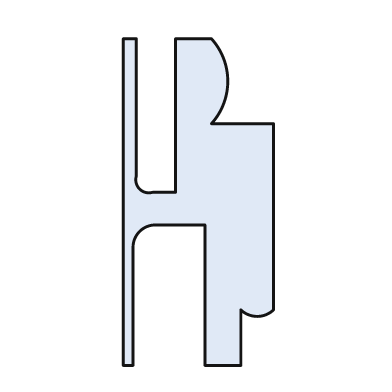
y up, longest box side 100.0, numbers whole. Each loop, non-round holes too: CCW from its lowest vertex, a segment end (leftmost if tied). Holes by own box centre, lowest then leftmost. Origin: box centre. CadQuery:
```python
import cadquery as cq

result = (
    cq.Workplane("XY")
    .moveTo(-23.0, -50.0)
    .lineTo(-20.0, -50.0)
    .lineTo(-20.0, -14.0)
    .threePointArc((-18.0, -9.0), (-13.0, -7.0))
    .lineTo(2.0, -7.0)
    .lineTo(2.0, -50.0)
    .lineTo(13.0, -50.0)
    .lineTo(13.0, -33.0)
    .threePointArc((18.0, -35.0), (23.0, -33.0))
    .lineTo(23.0, 24.0)
    .lineTo(4.0, 24.0)
    .threePointArc((9.0, 37.0), (4.0, 50.0))
    .lineTo(-7.0, 50.0)
    .lineTo(-7.0, 3.0)
    .lineTo(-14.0, 3.0)
    .threePointArc((-18.0, 4.0), (-19.0, 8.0))
    .lineTo(-19.0, 50.0)
    .lineTo(-23.0, 50.0)
    .close()
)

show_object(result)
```